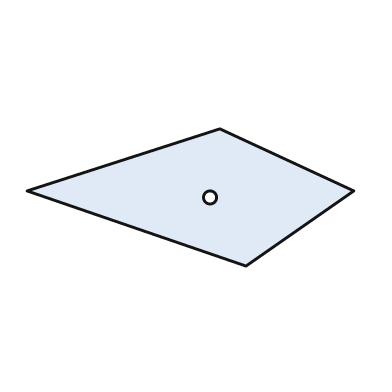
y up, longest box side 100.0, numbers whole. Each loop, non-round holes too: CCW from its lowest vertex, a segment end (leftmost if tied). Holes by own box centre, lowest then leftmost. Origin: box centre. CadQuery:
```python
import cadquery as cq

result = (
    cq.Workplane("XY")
    .moveTo(17.0, -21.0)
    .lineTo(50.0, 2.0)
    .lineTo(9.0, 21.0)
    .lineTo(-50.0, 2.0)
    .close()
    .moveTo(6.0, 0.0)
    .circle(2.0)
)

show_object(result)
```